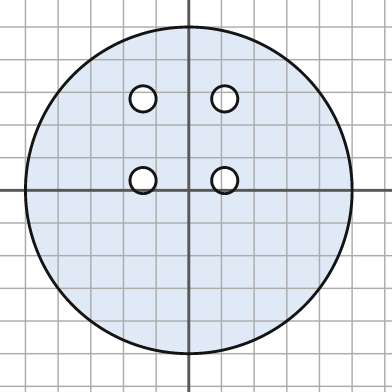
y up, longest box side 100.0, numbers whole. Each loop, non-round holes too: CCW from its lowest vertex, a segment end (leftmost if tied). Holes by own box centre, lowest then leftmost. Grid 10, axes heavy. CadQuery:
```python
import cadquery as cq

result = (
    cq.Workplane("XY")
    .moveTo(0.0, 0.0)
    .circle(50.0)
    .moveTo(-14.0, 3.0)
    .circle(4.0)
    .moveTo(11.0, 3.0)
    .circle(4.0)
    .moveTo(-14.0, 28.0)
    .circle(4.0)
    .moveTo(11.0, 28.0)
    .circle(4.0)
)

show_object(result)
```